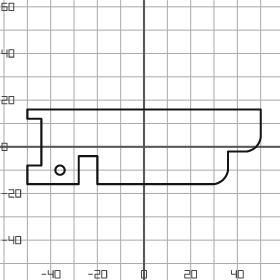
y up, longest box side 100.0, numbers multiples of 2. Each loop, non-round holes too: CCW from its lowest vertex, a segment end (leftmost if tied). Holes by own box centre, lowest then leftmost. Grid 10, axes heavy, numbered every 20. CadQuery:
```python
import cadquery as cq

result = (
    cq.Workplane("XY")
    .moveTo(-50.0, -16.0)
    .lineTo(-28.0, -16.0)
    .lineTo(-28.0, -4.0)
    .lineTo(-20.0, -4.0)
    .lineTo(-20.0, -16.0)
    .lineTo(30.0, -16.0)
    .threePointArc((34.0, -14.0), (36.0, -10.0))
    .lineTo(36.0, -2.0)
    .lineTo(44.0, -2.0)
    .threePointArc((48.0, 0.0), (50.0, 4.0))
    .lineTo(50.0, 16.0)
    .lineTo(-50.0, 16.0)
    .lineTo(-50.0, 12.0)
    .lineTo(-44.0, 12.0)
    .lineTo(-44.0, -8.0)
    .lineTo(-50.0, -8.0)
    .close()
    .moveTo(-36.0, -10.0)
    .circle(2.0)
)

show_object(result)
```